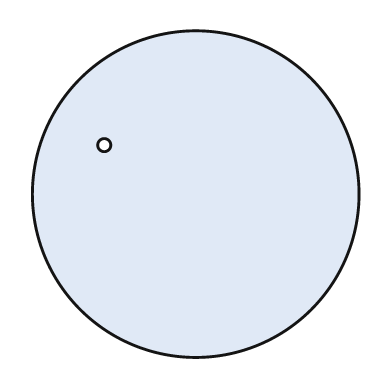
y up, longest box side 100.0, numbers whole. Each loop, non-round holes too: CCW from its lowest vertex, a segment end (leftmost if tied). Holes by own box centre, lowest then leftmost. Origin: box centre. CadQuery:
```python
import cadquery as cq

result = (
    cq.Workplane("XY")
    .moveTo(0.0, 0.0)
    .circle(50.0)
    .moveTo(-28.0, 15.0)
    .circle(2.0)
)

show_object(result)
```